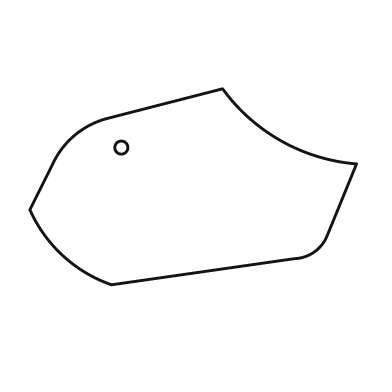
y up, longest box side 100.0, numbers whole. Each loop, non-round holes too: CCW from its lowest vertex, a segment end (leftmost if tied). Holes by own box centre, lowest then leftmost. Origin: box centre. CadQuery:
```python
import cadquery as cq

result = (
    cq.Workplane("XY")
    .moveTo(-25.0, -30.0)
    .lineTo(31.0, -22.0)
    .threePointArc((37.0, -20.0), (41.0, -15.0))
    .lineTo(50.0, 7.0)
    .threePointArc((27.0, 14.0), (9.0, 30.0))
    .lineTo(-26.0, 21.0)
    .threePointArc((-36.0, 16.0), (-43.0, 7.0))
    .lineTo(-50.0, -7.0)
    .threePointArc((-40.0, -21.0), (-25.0, -30.0))
    .close()
    .moveTo(-22.0, 12.0)
    .circle(2.0)
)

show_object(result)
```